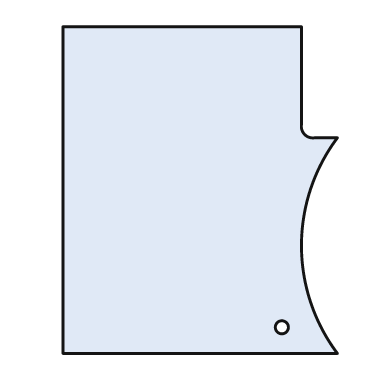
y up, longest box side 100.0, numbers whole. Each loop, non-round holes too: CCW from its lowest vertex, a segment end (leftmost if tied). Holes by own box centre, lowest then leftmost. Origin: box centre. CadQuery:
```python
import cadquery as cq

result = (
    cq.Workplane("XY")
    .moveTo(-42.0, -50.0)
    .lineTo(42.0, -50.0)
    .threePointArc((31.0, -17.0), (42.0, 16.0))
    .lineTo(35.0, 16.0)
    .threePointArc((32.0, 17.0), (31.0, 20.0))
    .lineTo(31.0, 50.0)
    .lineTo(-42.0, 50.0)
    .close()
    .moveTo(25.0, -42.0)
    .circle(2.0)
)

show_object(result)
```